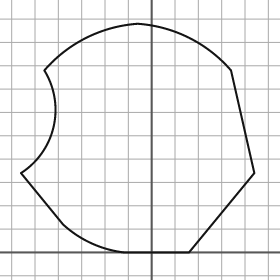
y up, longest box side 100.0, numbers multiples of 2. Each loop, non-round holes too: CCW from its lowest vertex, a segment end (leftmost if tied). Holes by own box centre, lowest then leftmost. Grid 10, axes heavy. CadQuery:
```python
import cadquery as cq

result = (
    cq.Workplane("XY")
    .moveTo(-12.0, 0.0)
    .lineTo(16.0, 0.0)
    .lineTo(44.0, 34.0)
    .lineTo(34.0, 78.0)
    .threePointArc((16.0, 92.0), (-6.0, 98.0))
    .threePointArc((-28.0, 92.0), (-46.0, 78.0))
    .threePointArc((-42.0, 54.0), (-56.0, 34.0))
    .lineTo(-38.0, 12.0)
    .threePointArc((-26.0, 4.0), (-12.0, 0.0))
    .close()
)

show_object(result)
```